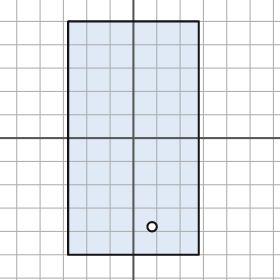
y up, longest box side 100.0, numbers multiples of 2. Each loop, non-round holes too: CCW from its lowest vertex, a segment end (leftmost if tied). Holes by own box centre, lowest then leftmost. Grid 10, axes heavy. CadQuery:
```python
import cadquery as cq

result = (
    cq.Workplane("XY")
    .moveTo(-28.0, -50.0)
    .lineTo(28.0, -50.0)
    .lineTo(28.0, 50.0)
    .lineTo(-28.0, 50.0)
    .close()
    .moveTo(8.0, -38.0)
    .circle(2.0)
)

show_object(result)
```